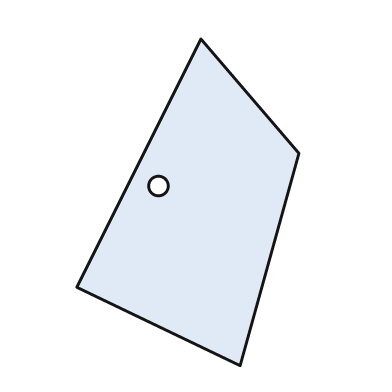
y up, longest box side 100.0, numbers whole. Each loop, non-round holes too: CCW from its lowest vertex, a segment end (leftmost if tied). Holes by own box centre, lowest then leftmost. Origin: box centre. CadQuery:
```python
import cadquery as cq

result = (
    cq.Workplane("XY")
    .moveTo(16.0, -50.0)
    .lineTo(34.0, 15.0)
    .lineTo(4.0, 50.0)
    .lineTo(-34.0, -26.0)
    .close()
    .moveTo(-9.0, 5.0)
    .circle(3.0)
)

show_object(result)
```